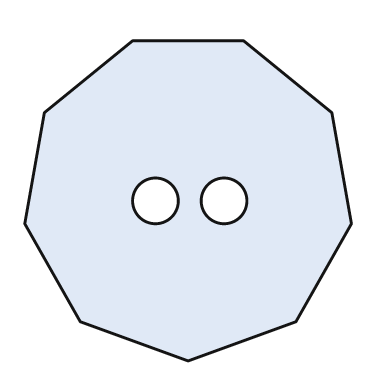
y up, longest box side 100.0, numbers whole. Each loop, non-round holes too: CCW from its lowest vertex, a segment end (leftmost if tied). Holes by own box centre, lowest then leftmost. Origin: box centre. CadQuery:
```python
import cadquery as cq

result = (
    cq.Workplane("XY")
    .moveTo(0.0, -49.0)
    .lineTo(33.0, -37.0)
    .lineTo(50.0, -7.0)
    .lineTo(44.0, 27.0)
    .lineTo(17.0, 49.0)
    .lineTo(-17.0, 49.0)
    .lineTo(-44.0, 27.0)
    .lineTo(-50.0, -7.0)
    .lineTo(-33.0, -37.0)
    .close()
    .moveTo(-10.0, 0.0)
    .circle(7.0)
    .moveTo(11.0, 0.0)
    .circle(7.0)
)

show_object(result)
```